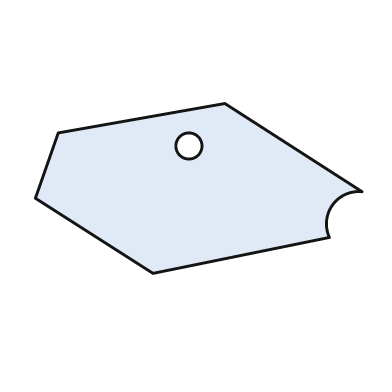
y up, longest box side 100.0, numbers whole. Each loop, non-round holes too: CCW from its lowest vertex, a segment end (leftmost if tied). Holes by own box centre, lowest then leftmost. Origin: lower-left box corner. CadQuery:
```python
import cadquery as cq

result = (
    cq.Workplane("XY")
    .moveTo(36.0, 0.0)
    .lineTo(90.0, 11.0)
    .threePointArc((91.0, 21.0), (100.0, 25.0))
    .lineTo(58.0, 52.0)
    .lineTo(7.0, 43.0)
    .lineTo(0.0, 23.0)
    .close()
    .moveTo(47.0, 39.0)
    .circle(4.0)
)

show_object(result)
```